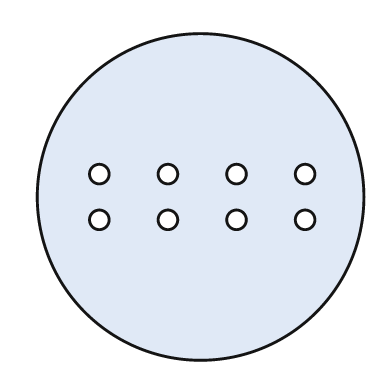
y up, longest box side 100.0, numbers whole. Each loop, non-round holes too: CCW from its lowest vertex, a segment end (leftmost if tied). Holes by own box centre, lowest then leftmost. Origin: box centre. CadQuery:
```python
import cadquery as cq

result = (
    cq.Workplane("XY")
    .moveTo(0.0, 0.0)
    .circle(50.0)
    .moveTo(-31.0, -7.0)
    .circle(3.0)
    .moveTo(-10.0, -7.0)
    .circle(3.0)
    .moveTo(11.0, -7.0)
    .circle(3.0)
    .moveTo(32.0, -7.0)
    .circle(3.0)
    .moveTo(-31.0, 7.0)
    .circle(3.0)
    .moveTo(-10.0, 7.0)
    .circle(3.0)
    .moveTo(11.0, 7.0)
    .circle(3.0)
    .moveTo(32.0, 7.0)
    .circle(3.0)
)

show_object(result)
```